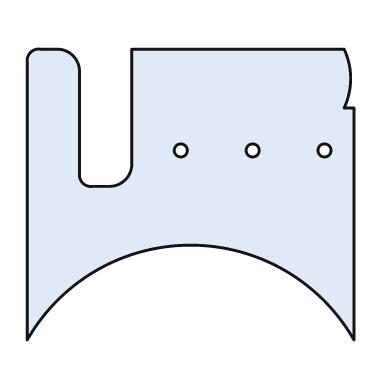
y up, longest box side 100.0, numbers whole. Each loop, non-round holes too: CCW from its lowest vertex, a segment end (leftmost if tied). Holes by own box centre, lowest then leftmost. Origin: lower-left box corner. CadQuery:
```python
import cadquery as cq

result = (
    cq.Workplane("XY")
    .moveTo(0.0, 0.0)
    .threePointArc((50.0, 29.0), (100.0, 0.0))
    .lineTo(100.0, 71.0)
    .lineTo(97.0, 71.0)
    .threePointArc((99.0, 80.0), (97.0, 89.0))
    .lineTo(32.0, 89.0)
    .lineTo(32.0, 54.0)
    .threePointArc((30.0, 49.0), (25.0, 47.0))
    .lineTo(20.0, 47.0)
    .threePointArc((17.0, 48.0), (16.0, 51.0))
    .lineTo(16.0, 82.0)
    .threePointArc((14.0, 87.0), (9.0, 89.0))
    .lineTo(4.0, 89.0)
    .threePointArc((1.0, 88.0), (0.0, 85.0))
    .close()
    .moveTo(47.0, 58.0)
    .circle(2.0)
    .moveTo(69.0, 58.0)
    .circle(2.0)
    .moveTo(91.0, 58.0)
    .circle(2.0)
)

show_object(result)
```